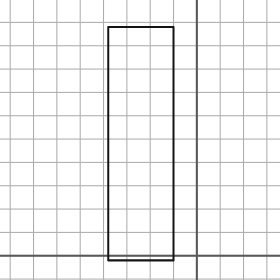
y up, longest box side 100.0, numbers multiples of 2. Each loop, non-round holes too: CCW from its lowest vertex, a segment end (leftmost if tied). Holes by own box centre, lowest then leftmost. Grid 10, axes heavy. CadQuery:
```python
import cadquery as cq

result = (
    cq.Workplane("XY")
    .moveTo(-38.0, -2.0)
    .lineTo(-10.0, -2.0)
    .lineTo(-10.0, 98.0)
    .lineTo(-38.0, 98.0)
    .close()
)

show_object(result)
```